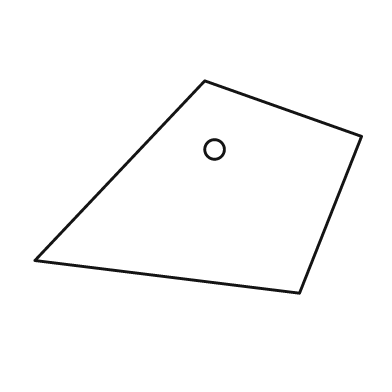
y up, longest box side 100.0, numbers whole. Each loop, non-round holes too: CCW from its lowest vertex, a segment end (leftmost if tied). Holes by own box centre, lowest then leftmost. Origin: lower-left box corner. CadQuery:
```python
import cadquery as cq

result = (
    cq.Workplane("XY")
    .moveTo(81.0, 0.0)
    .lineTo(100.0, 48.0)
    .lineTo(52.0, 65.0)
    .lineTo(0.0, 10.0)
    .close()
    .moveTo(55.0, 44.0)
    .circle(3.0)
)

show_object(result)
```